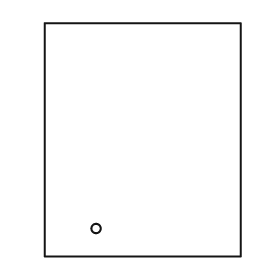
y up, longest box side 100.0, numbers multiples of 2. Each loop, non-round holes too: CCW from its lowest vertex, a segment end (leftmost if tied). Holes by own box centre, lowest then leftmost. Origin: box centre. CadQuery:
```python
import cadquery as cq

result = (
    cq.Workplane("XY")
    .moveTo(-42.0, -50.0)
    .lineTo(42.0, -50.0)
    .lineTo(42.0, 50.0)
    .lineTo(-42.0, 50.0)
    .close()
    .moveTo(-20.0, -38.0)
    .circle(2.0)
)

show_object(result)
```